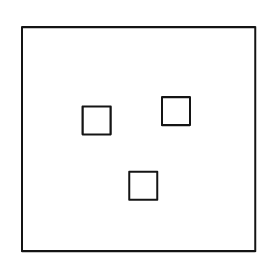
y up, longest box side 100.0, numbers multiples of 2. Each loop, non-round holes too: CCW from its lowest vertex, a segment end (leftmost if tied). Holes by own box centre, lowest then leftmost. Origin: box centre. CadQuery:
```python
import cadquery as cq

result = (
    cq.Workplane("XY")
    .moveTo(-50.0, -48.0)
    .lineTo(50.0, -48.0)
    .lineTo(50.0, 48.0)
    .lineTo(-50.0, 48.0)
    .close()
    .moveTo(-4.0, -26.0)
    .lineTo(8.0, -26.0)
    .lineTo(8.0, -14.0)
    .lineTo(-4.0, -14.0)
    .close()
    .moveTo(-24.0, 2.0)
    .lineTo(-12.0, 2.0)
    .lineTo(-12.0, 14.0)
    .lineTo(-24.0, 14.0)
    .close()
    .moveTo(10.0, 6.0)
    .lineTo(22.0, 6.0)
    .lineTo(22.0, 18.0)
    .lineTo(10.0, 18.0)
    .close()
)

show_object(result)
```